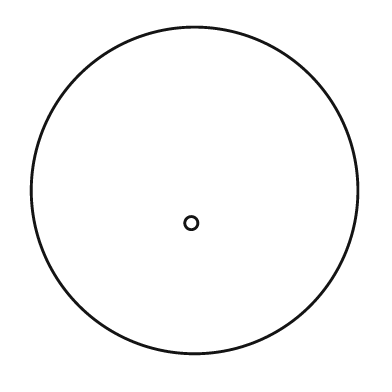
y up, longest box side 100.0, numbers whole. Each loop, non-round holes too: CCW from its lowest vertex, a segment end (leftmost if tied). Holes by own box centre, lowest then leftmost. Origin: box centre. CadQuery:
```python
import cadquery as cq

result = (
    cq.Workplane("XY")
    .moveTo(0.0, 0.0)
    .circle(50.0)
    .moveTo(-1.0, -10.0)
    .circle(2.0)
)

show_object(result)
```